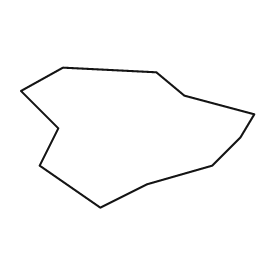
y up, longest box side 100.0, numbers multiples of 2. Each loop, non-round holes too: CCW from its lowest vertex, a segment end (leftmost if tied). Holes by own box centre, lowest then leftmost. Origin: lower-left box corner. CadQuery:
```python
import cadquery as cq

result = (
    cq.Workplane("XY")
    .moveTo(34.0, 0.0)
    .lineTo(54.0, 10.0)
    .lineTo(82.0, 18.0)
    .lineTo(94.0, 30.0)
    .lineTo(100.0, 40.0)
    .lineTo(70.0, 48.0)
    .lineTo(58.0, 58.0)
    .lineTo(18.0, 60.0)
    .lineTo(0.0, 50.0)
    .lineTo(16.0, 34.0)
    .lineTo(8.0, 18.0)
    .close()
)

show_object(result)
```